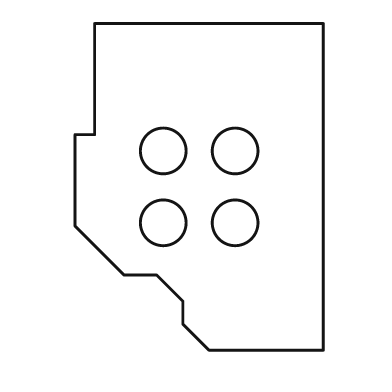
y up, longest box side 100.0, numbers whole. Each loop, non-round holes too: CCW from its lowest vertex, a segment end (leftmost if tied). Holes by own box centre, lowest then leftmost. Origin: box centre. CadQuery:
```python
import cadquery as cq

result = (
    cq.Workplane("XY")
    .moveTo(3.0, -50.0)
    .lineTo(38.0, -50.0)
    .lineTo(38.0, 50.0)
    .lineTo(-32.0, 50.0)
    .lineTo(-32.0, 16.0)
    .lineTo(-38.0, 16.0)
    .lineTo(-38.0, -12.0)
    .lineTo(-23.0, -27.0)
    .lineTo(-13.0, -27.0)
    .lineTo(-5.0, -35.0)
    .lineTo(-5.0, -42.0)
    .close()
    .moveTo(-11.0, -11.0)
    .circle(7.0)
    .moveTo(11.0, -11.0)
    .circle(7.0)
    .moveTo(-11.0, 11.0)
    .circle(7.0)
    .moveTo(11.0, 11.0)
    .circle(7.0)
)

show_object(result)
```